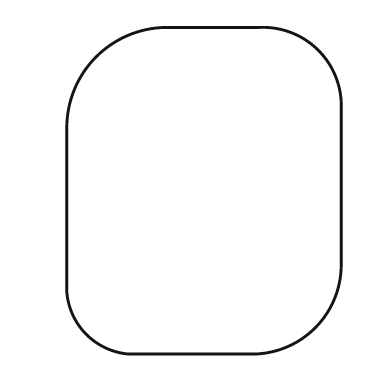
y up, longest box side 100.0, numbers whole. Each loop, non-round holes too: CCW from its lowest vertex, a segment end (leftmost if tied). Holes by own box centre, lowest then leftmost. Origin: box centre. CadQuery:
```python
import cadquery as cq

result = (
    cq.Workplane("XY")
    .moveTo(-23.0, -50.0)
    .lineTo(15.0, -50.0)
    .threePointArc((34.0, -42.0), (42.0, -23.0))
    .lineTo(42.0, 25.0)
    .threePointArc((35.0, 43.0), (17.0, 50.0))
    .lineTo(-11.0, 50.0)
    .threePointArc((-33.0, 41.0), (-42.0, 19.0))
    .lineTo(-42.0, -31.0)
    .threePointArc((-36.0, -44.0), (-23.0, -50.0))
    .close()
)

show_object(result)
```